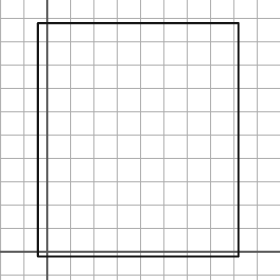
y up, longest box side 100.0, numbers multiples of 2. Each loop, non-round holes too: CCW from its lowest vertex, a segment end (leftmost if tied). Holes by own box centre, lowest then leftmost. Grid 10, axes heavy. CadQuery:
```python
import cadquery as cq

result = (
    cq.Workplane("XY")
    .moveTo(-4.0, -2.0)
    .lineTo(82.0, -2.0)
    .lineTo(82.0, 98.0)
    .lineTo(-4.0, 98.0)
    .close()
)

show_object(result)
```